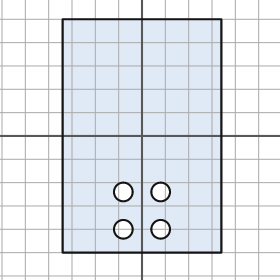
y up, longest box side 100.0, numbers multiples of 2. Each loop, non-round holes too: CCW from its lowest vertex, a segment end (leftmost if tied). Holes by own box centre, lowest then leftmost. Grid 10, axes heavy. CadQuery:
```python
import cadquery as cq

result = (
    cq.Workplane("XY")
    .moveTo(-34.0, -50.0)
    .lineTo(34.0, -50.0)
    .lineTo(34.0, 50.0)
    .lineTo(-34.0, 50.0)
    .close()
    .moveTo(-8.0, -40.0)
    .circle(4.0)
    .moveTo(8.0, -40.0)
    .circle(4.0)
    .moveTo(-8.0, -24.0)
    .circle(4.0)
    .moveTo(8.0, -24.0)
    .circle(4.0)
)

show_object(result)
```